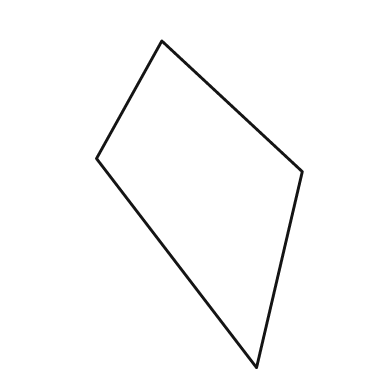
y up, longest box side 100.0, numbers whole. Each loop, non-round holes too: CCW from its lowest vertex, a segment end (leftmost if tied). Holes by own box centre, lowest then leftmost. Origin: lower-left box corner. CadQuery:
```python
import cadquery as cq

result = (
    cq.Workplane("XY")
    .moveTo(49.0, 0.0)
    .lineTo(63.0, 60.0)
    .lineTo(20.0, 100.0)
    .lineTo(0.0, 64.0)
    .close()
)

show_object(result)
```